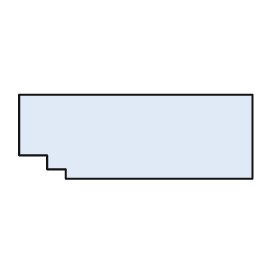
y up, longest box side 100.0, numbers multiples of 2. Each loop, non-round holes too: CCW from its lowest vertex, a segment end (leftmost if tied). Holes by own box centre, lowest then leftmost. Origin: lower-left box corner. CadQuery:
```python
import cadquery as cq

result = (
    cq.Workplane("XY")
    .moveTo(20.0, 0.0)
    .lineTo(100.0, 0.0)
    .lineTo(100.0, 36.0)
    .lineTo(0.0, 36.0)
    .lineTo(0.0, 10.0)
    .lineTo(12.0, 10.0)
    .lineTo(12.0, 4.0)
    .lineTo(20.0, 4.0)
    .close()
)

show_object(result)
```